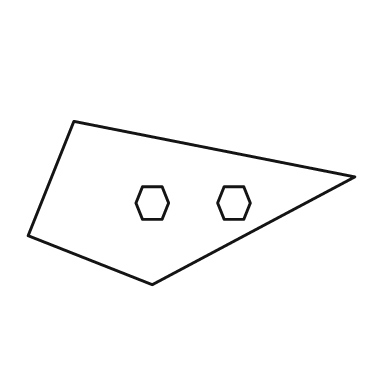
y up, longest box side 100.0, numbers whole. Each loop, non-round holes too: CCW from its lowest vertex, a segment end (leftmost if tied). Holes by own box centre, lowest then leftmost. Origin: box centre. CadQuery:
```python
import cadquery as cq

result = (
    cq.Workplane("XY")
    .moveTo(-12.0, -25.0)
    .lineTo(50.0, 8.0)
    .lineTo(-36.0, 25.0)
    .lineTo(-50.0, -10.0)
    .close()
    .moveTo(-15.0, -5.0)
    .lineTo(-9.0, -5.0)
    .lineTo(-7.0, 0.0)
    .lineTo(-9.0, 5.0)
    .lineTo(-15.0, 5.0)
    .lineTo(-17.0, 0.0)
    .close()
    .moveTo(10.0, -5.0)
    .lineTo(16.0, -5.0)
    .lineTo(18.0, 0.0)
    .lineTo(16.0, 5.0)
    .lineTo(10.0, 5.0)
    .lineTo(8.0, 0.0)
    .close()
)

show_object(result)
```